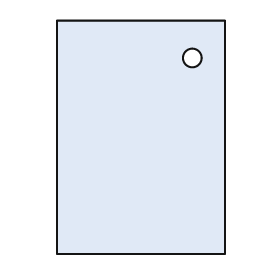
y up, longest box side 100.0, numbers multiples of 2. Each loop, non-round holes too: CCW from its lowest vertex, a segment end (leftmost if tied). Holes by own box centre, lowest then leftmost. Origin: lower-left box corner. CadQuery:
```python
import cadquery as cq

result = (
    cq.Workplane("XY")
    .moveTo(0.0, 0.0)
    .lineTo(72.0, 0.0)
    .lineTo(72.0, 100.0)
    .lineTo(0.0, 100.0)
    .close()
    .moveTo(58.0, 84.0)
    .circle(4.0)
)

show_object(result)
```